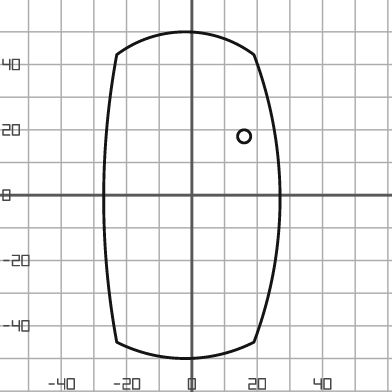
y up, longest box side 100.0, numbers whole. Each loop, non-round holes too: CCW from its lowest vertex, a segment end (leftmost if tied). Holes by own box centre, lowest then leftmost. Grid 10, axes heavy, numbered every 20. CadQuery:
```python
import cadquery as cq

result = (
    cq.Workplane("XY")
    .moveTo(-23.0, -45.0)
    .threePointArc((-2.0, -50.0), (19.0, -45.0))
    .threePointArc((27.0, -1.0), (19.0, 43.0))
    .threePointArc((-2.0, 50.0), (-23.0, 43.0))
    .threePointArc((-27.0, -1.0), (-23.0, -45.0))
    .close()
    .moveTo(16.0, 18.0)
    .circle(2.0)
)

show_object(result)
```